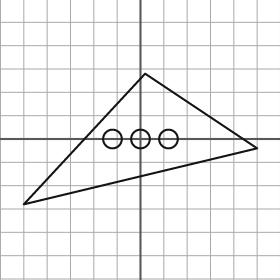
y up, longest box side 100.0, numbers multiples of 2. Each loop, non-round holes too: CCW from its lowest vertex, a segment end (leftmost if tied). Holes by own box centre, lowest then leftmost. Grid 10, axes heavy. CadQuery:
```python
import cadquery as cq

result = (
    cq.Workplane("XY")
    .moveTo(-50.0, -28.0)
    .lineTo(50.0, -4.0)
    .lineTo(2.0, 28.0)
    .close()
    .moveTo(-12.0, 0.0)
    .circle(4.0)
    .moveTo(0.0, 0.0)
    .circle(4.0)
    .moveTo(12.0, 0.0)
    .circle(4.0)
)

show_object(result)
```